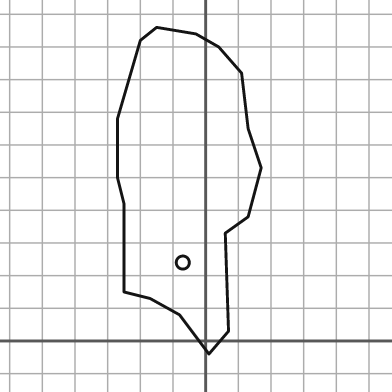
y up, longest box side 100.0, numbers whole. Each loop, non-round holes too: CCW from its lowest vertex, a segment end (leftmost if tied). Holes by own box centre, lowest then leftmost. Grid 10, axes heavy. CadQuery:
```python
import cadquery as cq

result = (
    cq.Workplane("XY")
    .moveTo(1.0, -4.0)
    .lineTo(7.0, 3.0)
    .lineTo(6.0, 33.0)
    .lineTo(13.0, 38.0)
    .lineTo(17.0, 53.0)
    .lineTo(13.0, 65.0)
    .lineTo(11.0, 82.0)
    .lineTo(4.0, 90.0)
    .lineTo(-3.0, 94.0)
    .lineTo(-15.0, 96.0)
    .lineTo(-20.0, 92.0)
    .lineTo(-27.0, 68.0)
    .lineTo(-27.0, 50.0)
    .lineTo(-25.0, 42.0)
    .lineTo(-25.0, 15.0)
    .lineTo(-17.0, 13.0)
    .lineTo(-8.0, 8.0)
    .close()
    .moveTo(-7.0, 24.0)
    .circle(2.0)
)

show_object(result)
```